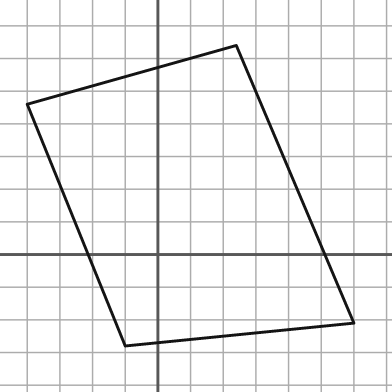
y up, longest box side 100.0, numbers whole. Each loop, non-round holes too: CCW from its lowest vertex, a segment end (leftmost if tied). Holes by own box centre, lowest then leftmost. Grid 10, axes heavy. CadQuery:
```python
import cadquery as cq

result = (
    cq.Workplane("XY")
    .moveTo(-10.0, -28.0)
    .lineTo(60.0, -21.0)
    .lineTo(24.0, 64.0)
    .lineTo(-40.0, 46.0)
    .close()
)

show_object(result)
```